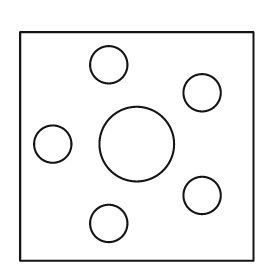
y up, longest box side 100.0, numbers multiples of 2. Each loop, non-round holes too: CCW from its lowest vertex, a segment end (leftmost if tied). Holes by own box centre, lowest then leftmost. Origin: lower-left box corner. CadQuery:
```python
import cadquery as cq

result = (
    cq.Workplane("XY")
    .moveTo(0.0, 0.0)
    .lineTo(100.0, 0.0)
    .lineTo(100.0, 98.0)
    .lineTo(0.0, 98.0)
    .close()
    .moveTo(38.0, 16.0)
    .circle(8.0)
    .moveTo(78.0, 28.0)
    .circle(8.0)
    .moveTo(14.0, 50.0)
    .circle(8.0)
    .moveTo(50.0, 50.0)
    .circle(16.0)
    .moveTo(78.0, 72.0)
    .circle(8.0)
    .moveTo(38.0, 84.0)
    .circle(8.0)
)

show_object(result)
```